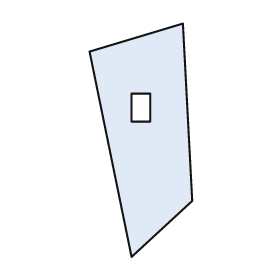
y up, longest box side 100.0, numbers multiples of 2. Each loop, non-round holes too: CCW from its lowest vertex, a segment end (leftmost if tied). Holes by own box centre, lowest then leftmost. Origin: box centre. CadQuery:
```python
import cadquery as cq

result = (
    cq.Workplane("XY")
    .moveTo(-4.0, -50.0)
    .lineTo(22.0, -26.0)
    .lineTo(18.0, 50.0)
    .lineTo(-22.0, 38.0)
    .close()
    .moveTo(-4.0, 8.0)
    .lineTo(4.0, 8.0)
    .lineTo(4.0, 20.0)
    .lineTo(-4.0, 20.0)
    .close()
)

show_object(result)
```